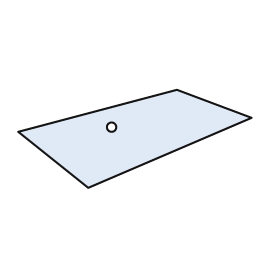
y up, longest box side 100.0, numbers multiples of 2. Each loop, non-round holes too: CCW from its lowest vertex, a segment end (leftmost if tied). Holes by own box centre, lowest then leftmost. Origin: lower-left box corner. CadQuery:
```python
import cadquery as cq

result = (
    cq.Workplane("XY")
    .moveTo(30.0, 0.0)
    .lineTo(100.0, 30.0)
    .lineTo(68.0, 42.0)
    .lineTo(0.0, 24.0)
    .close()
    .moveTo(40.0, 26.0)
    .circle(2.0)
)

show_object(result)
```